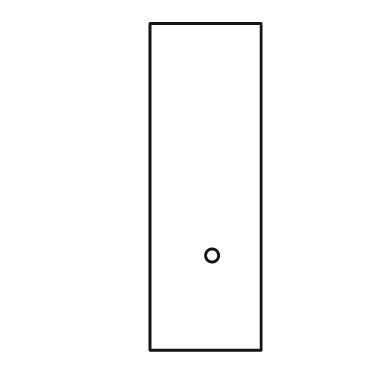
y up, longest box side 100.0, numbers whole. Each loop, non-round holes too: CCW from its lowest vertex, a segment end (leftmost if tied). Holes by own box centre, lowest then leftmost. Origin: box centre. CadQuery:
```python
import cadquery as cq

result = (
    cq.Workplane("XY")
    .moveTo(-17.0, -50.0)
    .lineTo(17.0, -50.0)
    .lineTo(17.0, 50.0)
    .lineTo(-17.0, 50.0)
    .close()
    .moveTo(2.0, -21.0)
    .circle(2.0)
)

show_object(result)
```